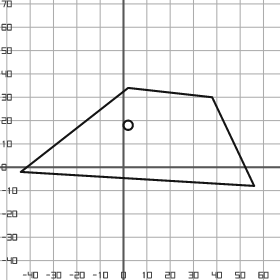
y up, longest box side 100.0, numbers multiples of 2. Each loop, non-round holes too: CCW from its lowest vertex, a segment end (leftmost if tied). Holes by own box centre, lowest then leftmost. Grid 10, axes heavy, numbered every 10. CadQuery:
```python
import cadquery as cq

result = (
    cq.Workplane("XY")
    .moveTo(56.0, -8.0)
    .lineTo(38.0, 30.0)
    .lineTo(2.0, 34.0)
    .lineTo(-44.0, -2.0)
    .close()
    .moveTo(2.0, 18.0)
    .circle(2.0)
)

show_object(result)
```